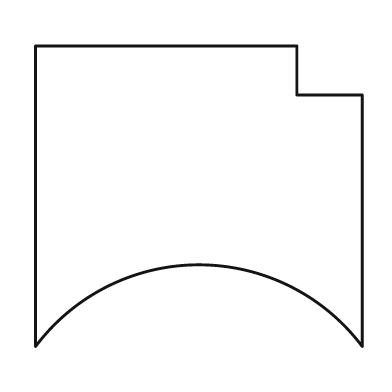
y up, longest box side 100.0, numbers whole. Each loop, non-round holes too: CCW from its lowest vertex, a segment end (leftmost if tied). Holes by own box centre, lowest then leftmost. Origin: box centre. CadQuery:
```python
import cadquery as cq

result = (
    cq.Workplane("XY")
    .moveTo(-50.0, -46.0)
    .threePointArc((0.0, -21.0), (50.0, -46.0))
    .lineTo(50.0, 31.0)
    .lineTo(30.0, 31.0)
    .lineTo(30.0, 46.0)
    .lineTo(-50.0, 46.0)
    .close()
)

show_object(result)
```